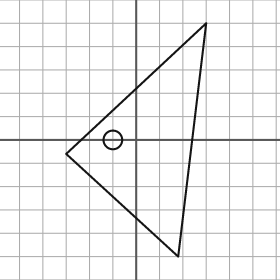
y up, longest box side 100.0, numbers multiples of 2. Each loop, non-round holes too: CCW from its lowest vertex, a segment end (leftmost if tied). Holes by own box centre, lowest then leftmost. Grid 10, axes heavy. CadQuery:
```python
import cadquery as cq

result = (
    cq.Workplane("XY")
    .moveTo(18.0, -50.0)
    .lineTo(30.0, 50.0)
    .lineTo(-30.0, -6.0)
    .close()
    .moveTo(-10.0, 0.0)
    .circle(4.0)
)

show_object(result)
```